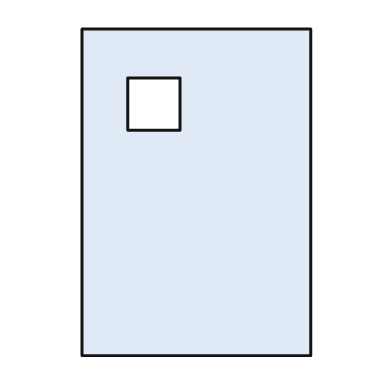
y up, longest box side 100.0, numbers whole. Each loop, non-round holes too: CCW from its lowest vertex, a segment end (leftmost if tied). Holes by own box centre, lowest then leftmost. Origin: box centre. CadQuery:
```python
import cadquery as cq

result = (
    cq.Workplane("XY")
    .moveTo(-35.0, -50.0)
    .lineTo(35.0, -50.0)
    .lineTo(35.0, 50.0)
    .lineTo(-35.0, 50.0)
    .close()
    .moveTo(-21.0, 19.0)
    .lineTo(-5.0, 19.0)
    .lineTo(-5.0, 35.0)
    .lineTo(-21.0, 35.0)
    .close()
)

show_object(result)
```